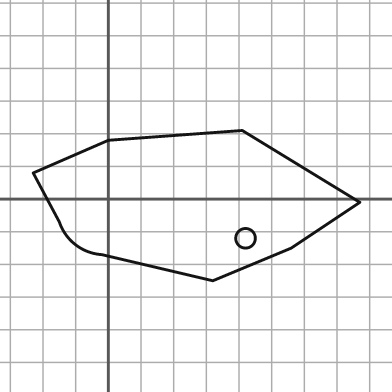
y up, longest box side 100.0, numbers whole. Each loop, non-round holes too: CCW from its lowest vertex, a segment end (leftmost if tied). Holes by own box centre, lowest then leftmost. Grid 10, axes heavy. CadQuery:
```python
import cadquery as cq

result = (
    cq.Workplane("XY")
    .moveTo(32.0, -25.0)
    .lineTo(56.0, -15.0)
    .lineTo(77.0, -1.0)
    .lineTo(41.0, 21.0)
    .lineTo(0.0, 18.0)
    .lineTo(-23.0, 8.0)
    .lineTo(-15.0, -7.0)
    .threePointArc((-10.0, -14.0), (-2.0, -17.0))
    .close()
    .moveTo(42.0, -12.0)
    .circle(3.0)
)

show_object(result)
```